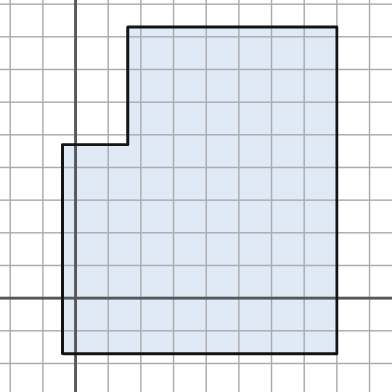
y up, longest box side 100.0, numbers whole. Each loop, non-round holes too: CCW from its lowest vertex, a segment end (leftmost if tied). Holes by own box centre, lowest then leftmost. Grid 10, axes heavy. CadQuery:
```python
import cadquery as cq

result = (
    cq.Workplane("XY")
    .moveTo(-4.0, -17.0)
    .lineTo(80.0, -17.0)
    .lineTo(80.0, 83.0)
    .lineTo(16.0, 83.0)
    .lineTo(16.0, 47.0)
    .lineTo(-4.0, 47.0)
    .close()
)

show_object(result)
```